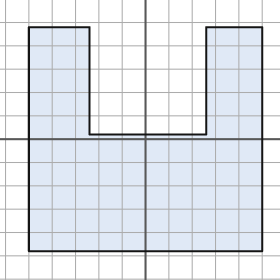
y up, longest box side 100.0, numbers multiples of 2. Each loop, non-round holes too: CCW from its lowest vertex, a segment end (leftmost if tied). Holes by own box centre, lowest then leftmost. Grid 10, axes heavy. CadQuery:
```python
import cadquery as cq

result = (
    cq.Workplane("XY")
    .moveTo(-50.0, -48.0)
    .lineTo(50.0, -48.0)
    .lineTo(50.0, 48.0)
    .lineTo(26.0, 48.0)
    .lineTo(26.0, 2.0)
    .lineTo(-24.0, 2.0)
    .lineTo(-24.0, 48.0)
    .lineTo(-50.0, 48.0)
    .close()
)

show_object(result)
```